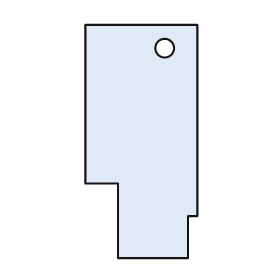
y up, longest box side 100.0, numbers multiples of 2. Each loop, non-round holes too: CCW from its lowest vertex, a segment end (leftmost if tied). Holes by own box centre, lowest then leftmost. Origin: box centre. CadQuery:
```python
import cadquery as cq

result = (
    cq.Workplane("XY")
    .moveTo(-10.0, -50.0)
    .lineTo(20.0, -50.0)
    .lineTo(20.0, -32.0)
    .lineTo(24.0, -32.0)
    .lineTo(24.0, 50.0)
    .lineTo(-24.0, 50.0)
    .lineTo(-24.0, -18.0)
    .lineTo(-10.0, -18.0)
    .close()
    .moveTo(10.0, 40.0)
    .circle(4.0)
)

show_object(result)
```